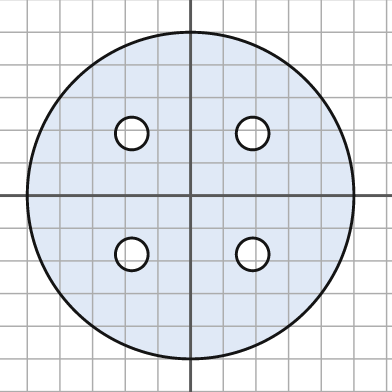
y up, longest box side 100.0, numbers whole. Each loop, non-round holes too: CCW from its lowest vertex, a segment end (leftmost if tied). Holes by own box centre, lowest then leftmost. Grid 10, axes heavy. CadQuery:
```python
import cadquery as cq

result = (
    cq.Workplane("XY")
    .moveTo(0.0, 0.0)
    .circle(50.0)
    .moveTo(-18.0, -18.0)
    .circle(5.0)
    .moveTo(19.0, -18.0)
    .circle(5.0)
    .moveTo(-18.0, 19.0)
    .circle(5.0)
    .moveTo(19.0, 19.0)
    .circle(5.0)
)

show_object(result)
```